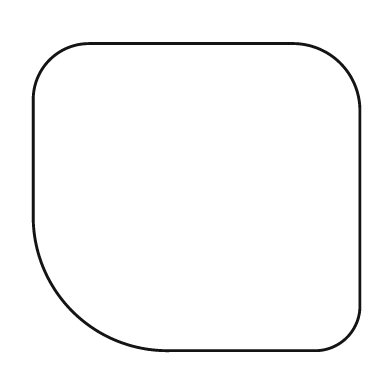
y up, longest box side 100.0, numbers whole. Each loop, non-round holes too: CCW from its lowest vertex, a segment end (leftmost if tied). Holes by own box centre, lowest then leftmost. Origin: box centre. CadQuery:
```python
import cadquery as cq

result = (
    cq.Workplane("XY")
    .moveTo(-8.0, -47.0)
    .lineTo(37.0, -47.0)
    .threePointArc((46.0, -43.0), (50.0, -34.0))
    .lineTo(50.0, 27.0)
    .threePointArc((44.0, 41.0), (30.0, 47.0))
    .lineTo(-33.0, 47.0)
    .threePointArc((-45.0, 42.0), (-50.0, 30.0))
    .lineTo(-50.0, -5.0)
    .threePointArc((-38.0, -35.0), (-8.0, -47.0))
    .close()
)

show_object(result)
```